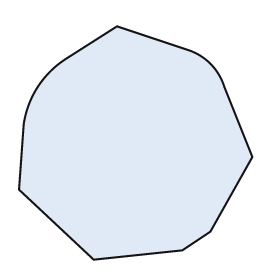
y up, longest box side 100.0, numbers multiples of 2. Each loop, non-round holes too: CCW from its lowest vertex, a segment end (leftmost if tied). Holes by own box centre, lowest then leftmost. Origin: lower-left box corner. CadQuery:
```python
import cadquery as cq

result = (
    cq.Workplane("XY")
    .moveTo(32.0, 0.0)
    .lineTo(70.0, 4.0)
    .lineTo(82.0, 12.0)
    .lineTo(100.0, 44.0)
    .lineTo(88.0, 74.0)
    .threePointArc((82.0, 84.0), (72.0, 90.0))
    .lineTo(42.0, 100.0)
    .lineTo(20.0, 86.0)
    .threePointArc((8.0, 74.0), (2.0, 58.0))
    .lineTo(0.0, 30.0)
    .close()
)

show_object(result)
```